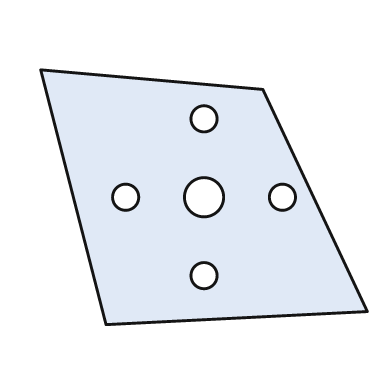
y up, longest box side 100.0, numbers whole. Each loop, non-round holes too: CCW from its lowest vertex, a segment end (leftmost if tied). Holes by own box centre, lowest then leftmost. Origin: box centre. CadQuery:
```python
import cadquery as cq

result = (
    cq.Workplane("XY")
    .moveTo(-30.0, -39.0)
    .lineTo(50.0, -35.0)
    .lineTo(18.0, 33.0)
    .lineTo(-50.0, 39.0)
    .close()
    .moveTo(0.0, -24.0)
    .circle(4.0)
    .moveTo(-24.0, 0.0)
    .circle(4.0)
    .moveTo(0.0, 0.0)
    .circle(6.0)
    .moveTo(24.0, 0.0)
    .circle(4.0)
    .moveTo(0.0, 24.0)
    .circle(4.0)
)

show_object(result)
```